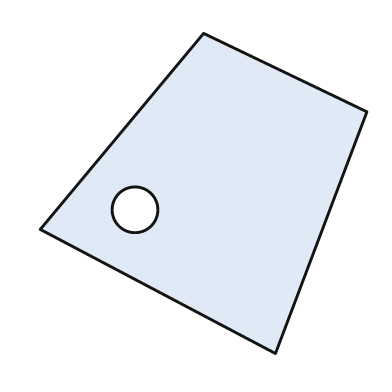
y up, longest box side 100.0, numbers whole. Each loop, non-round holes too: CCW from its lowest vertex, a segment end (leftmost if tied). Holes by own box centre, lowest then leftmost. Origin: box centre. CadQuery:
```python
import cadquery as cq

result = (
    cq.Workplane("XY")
    .moveTo(22.0, -49.0)
    .lineTo(50.0, 25.0)
    .lineTo(0.0, 49.0)
    .lineTo(-50.0, -11.0)
    .close()
    .moveTo(-21.0, -5.0)
    .circle(7.0)
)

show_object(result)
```